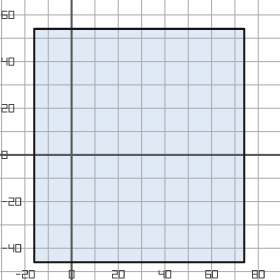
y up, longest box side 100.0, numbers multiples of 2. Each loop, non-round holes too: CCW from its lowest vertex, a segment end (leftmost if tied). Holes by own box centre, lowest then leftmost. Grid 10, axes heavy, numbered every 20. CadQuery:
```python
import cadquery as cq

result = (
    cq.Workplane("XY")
    .moveTo(-16.0, -46.0)
    .lineTo(74.0, -46.0)
    .lineTo(74.0, 54.0)
    .lineTo(-16.0, 54.0)
    .close()
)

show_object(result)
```